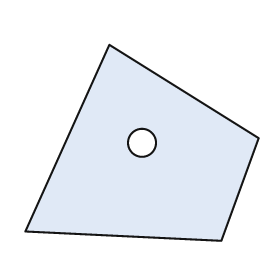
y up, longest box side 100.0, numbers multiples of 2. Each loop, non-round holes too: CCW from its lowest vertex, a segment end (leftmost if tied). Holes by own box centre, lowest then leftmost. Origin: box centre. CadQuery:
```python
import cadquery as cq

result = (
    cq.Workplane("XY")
    .moveTo(34.0, -42.0)
    .lineTo(50.0, 2.0)
    .lineTo(-14.0, 42.0)
    .lineTo(-50.0, -38.0)
    .close()
    .moveTo(0.0, 0.0)
    .circle(6.0)
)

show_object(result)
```